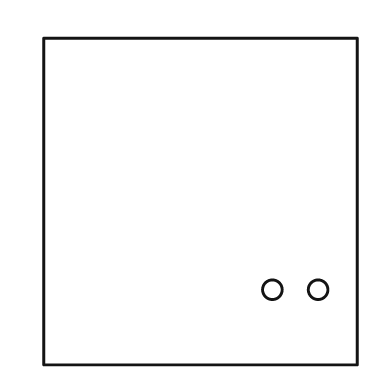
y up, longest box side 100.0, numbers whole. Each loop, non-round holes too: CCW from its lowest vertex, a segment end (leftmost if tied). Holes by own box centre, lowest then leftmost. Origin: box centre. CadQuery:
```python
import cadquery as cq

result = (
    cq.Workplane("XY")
    .moveTo(-48.0, -50.0)
    .lineTo(48.0, -50.0)
    .lineTo(48.0, 50.0)
    .lineTo(-48.0, 50.0)
    .close()
    .moveTo(22.0, -27.0)
    .circle(3.0)
    .moveTo(36.0, -27.0)
    .circle(3.0)
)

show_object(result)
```